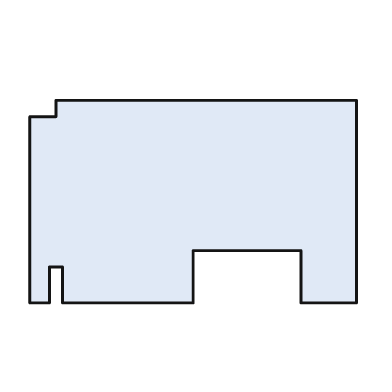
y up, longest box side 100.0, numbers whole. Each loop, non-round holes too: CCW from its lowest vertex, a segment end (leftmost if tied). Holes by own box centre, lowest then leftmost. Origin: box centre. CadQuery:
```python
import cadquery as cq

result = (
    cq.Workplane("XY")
    .moveTo(-50.0, -31.0)
    .lineTo(-44.0, -31.0)
    .lineTo(-44.0, -20.0)
    .lineTo(-40.0, -20.0)
    .lineTo(-40.0, -31.0)
    .lineTo(0.0, -31.0)
    .lineTo(0.0, -15.0)
    .lineTo(33.0, -15.0)
    .lineTo(33.0, -31.0)
    .lineTo(50.0, -31.0)
    .lineTo(50.0, 31.0)
    .lineTo(-42.0, 31.0)
    .lineTo(-42.0, 26.0)
    .lineTo(-50.0, 26.0)
    .close()
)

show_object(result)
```